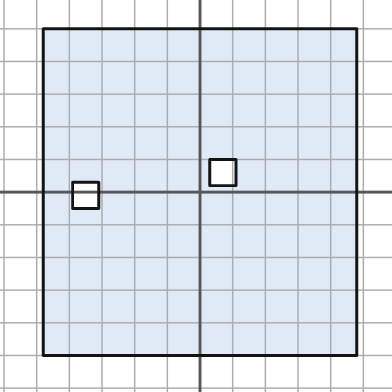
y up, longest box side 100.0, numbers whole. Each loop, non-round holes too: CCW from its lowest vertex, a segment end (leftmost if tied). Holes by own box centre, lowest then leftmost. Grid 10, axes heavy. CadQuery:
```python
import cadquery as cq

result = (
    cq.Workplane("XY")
    .moveTo(-48.0, -50.0)
    .lineTo(48.0, -50.0)
    .lineTo(48.0, 50.0)
    .lineTo(-48.0, 50.0)
    .close()
    .moveTo(-39.0, -5.0)
    .lineTo(-31.0, -5.0)
    .lineTo(-31.0, 3.0)
    .lineTo(-39.0, 3.0)
    .close()
    .moveTo(3.0, 2.0)
    .lineTo(11.0, 2.0)
    .lineTo(11.0, 10.0)
    .lineTo(3.0, 10.0)
    .close()
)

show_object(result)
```